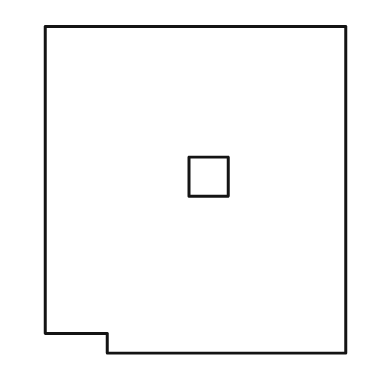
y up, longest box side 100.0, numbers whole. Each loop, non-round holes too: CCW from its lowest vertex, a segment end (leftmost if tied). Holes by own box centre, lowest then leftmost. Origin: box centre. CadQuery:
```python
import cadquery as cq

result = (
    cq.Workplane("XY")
    .moveTo(-27.0, -50.0)
    .lineTo(46.0, -50.0)
    .lineTo(46.0, 50.0)
    .lineTo(-46.0, 50.0)
    .lineTo(-46.0, -44.0)
    .lineTo(-27.0, -44.0)
    .close()
    .moveTo(-2.0, -2.0)
    .lineTo(10.0, -2.0)
    .lineTo(10.0, 10.0)
    .lineTo(-2.0, 10.0)
    .close()
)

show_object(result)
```